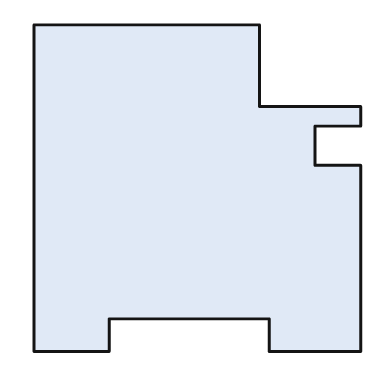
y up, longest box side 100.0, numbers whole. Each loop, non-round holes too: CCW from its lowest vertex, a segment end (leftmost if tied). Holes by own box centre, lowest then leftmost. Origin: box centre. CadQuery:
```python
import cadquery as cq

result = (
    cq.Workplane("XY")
    .moveTo(-50.0, -50.0)
    .lineTo(-27.0, -50.0)
    .lineTo(-27.0, -40.0)
    .lineTo(22.0, -40.0)
    .lineTo(22.0, -50.0)
    .lineTo(50.0, -50.0)
    .lineTo(50.0, 7.0)
    .lineTo(36.0, 7.0)
    .lineTo(36.0, 19.0)
    .lineTo(50.0, 19.0)
    .lineTo(50.0, 25.0)
    .lineTo(19.0, 25.0)
    .lineTo(19.0, 50.0)
    .lineTo(-50.0, 50.0)
    .close()
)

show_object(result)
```